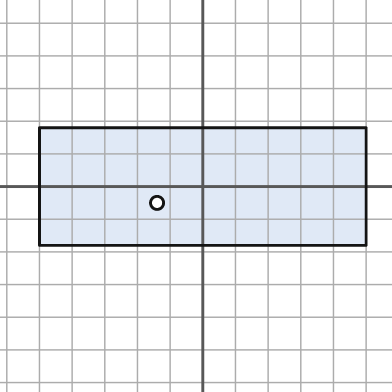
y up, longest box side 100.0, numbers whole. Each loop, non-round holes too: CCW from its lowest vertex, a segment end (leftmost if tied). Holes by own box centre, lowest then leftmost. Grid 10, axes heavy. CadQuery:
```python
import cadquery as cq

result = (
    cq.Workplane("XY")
    .moveTo(-50.0, -18.0)
    .lineTo(50.0, -18.0)
    .lineTo(50.0, 18.0)
    .lineTo(-50.0, 18.0)
    .close()
    .moveTo(-14.0, -5.0)
    .circle(2.0)
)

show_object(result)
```